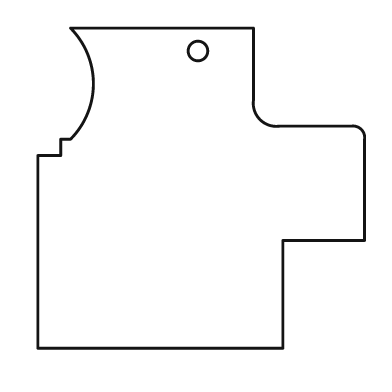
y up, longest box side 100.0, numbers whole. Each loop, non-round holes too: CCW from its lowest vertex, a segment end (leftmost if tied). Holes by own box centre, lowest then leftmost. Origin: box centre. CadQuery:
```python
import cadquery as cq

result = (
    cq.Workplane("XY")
    .moveTo(-50.0, -49.0)
    .lineTo(25.0, -49.0)
    .lineTo(25.0, -16.0)
    .lineTo(50.0, -16.0)
    .lineTo(50.0, 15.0)
    .threePointArc((49.0, 18.0), (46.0, 19.0))
    .lineTo(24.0, 19.0)
    .threePointArc((18.0, 21.0), (16.0, 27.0))
    .lineTo(16.0, 49.0)
    .lineTo(-40.0, 49.0)
    .threePointArc((-33.0, 32.0), (-40.0, 15.0))
    .lineTo(-43.0, 15.0)
    .lineTo(-43.0, 10.0)
    .lineTo(-50.0, 10.0)
    .close()
    .moveTo(-1.0, 42.0)
    .circle(3.0)
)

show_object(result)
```